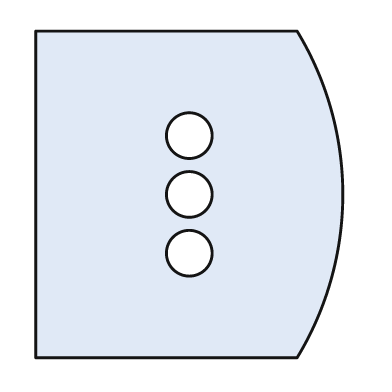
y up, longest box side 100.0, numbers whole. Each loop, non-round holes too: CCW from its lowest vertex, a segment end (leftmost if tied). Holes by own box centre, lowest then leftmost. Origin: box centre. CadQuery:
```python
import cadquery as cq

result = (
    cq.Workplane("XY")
    .moveTo(-47.0, -50.0)
    .lineTo(33.0, -50.0)
    .threePointArc((47.0, 0.0), (33.0, 50.0))
    .lineTo(-47.0, 50.0)
    .close()
    .moveTo(0.0, -18.0)
    .circle(7.0)
    .moveTo(0.0, 0.0)
    .circle(7.0)
    .moveTo(0.0, 18.0)
    .circle(7.0)
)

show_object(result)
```